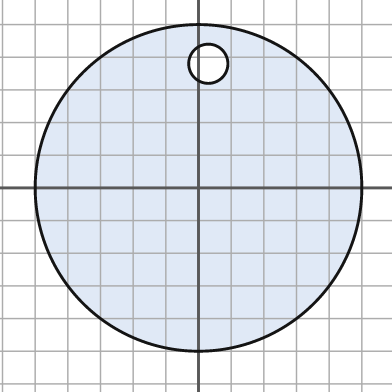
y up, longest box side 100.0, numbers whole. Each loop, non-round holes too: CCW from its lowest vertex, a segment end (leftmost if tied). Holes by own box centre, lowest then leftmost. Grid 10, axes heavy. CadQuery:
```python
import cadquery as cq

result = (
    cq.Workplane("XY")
    .moveTo(0.0, 0.0)
    .circle(50.0)
    .moveTo(3.0, 38.0)
    .circle(6.0)
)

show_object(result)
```